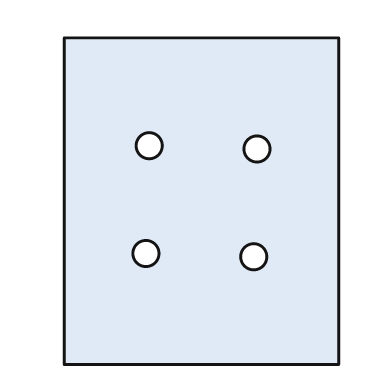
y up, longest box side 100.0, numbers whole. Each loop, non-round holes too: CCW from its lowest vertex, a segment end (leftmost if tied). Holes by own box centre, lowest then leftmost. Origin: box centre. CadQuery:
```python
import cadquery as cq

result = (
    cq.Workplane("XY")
    .moveTo(-42.0, -50.0)
    .lineTo(42.0, -50.0)
    .lineTo(42.0, 50.0)
    .lineTo(-42.0, 50.0)
    .close()
    .moveTo(16.0, -17.0)
    .circle(4.0)
    .moveTo(-17.0, -16.0)
    .circle(4.0)
    .moveTo(17.0, 16.0)
    .circle(4.0)
    .moveTo(-16.0, 17.0)
    .circle(4.0)
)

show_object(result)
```